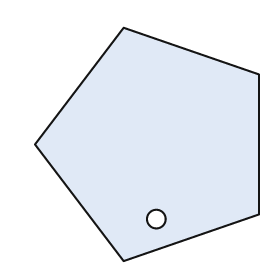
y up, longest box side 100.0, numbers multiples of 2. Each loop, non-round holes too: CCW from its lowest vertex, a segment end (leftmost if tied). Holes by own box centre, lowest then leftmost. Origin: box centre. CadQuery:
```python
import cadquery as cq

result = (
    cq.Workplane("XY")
    .moveTo(-10.0, -50.0)
    .lineTo(48.0, -30.0)
    .lineTo(48.0, 30.0)
    .lineTo(-10.0, 50.0)
    .lineTo(-48.0, 0.0)
    .close()
    .moveTo(4.0, -32.0)
    .circle(4.0)
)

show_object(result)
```